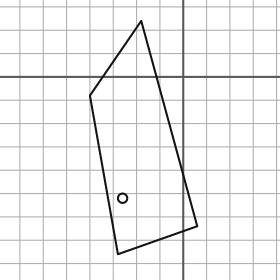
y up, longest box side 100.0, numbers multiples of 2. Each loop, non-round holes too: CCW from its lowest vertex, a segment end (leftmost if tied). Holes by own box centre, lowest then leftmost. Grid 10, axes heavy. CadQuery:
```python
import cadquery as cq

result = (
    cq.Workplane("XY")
    .moveTo(-28.0, -76.0)
    .lineTo(6.0, -64.0)
    .lineTo(-18.0, 24.0)
    .lineTo(-40.0, -8.0)
    .close()
    .moveTo(-26.0, -52.0)
    .circle(2.0)
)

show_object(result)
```